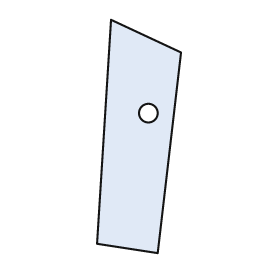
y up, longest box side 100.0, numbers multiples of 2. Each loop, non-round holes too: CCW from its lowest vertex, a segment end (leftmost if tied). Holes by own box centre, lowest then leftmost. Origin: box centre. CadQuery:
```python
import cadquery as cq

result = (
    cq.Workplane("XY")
    .moveTo(8.0, -50.0)
    .lineTo(18.0, 36.0)
    .lineTo(-12.0, 50.0)
    .lineTo(-18.0, -46.0)
    .close()
    .moveTo(4.0, 10.0)
    .circle(4.0)
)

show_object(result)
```